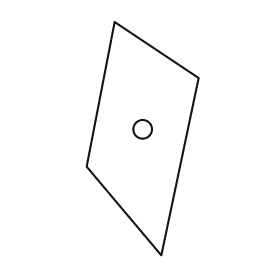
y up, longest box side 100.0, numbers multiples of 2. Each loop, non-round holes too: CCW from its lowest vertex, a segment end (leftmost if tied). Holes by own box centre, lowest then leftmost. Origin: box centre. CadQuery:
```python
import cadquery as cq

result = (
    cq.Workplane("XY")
    .moveTo(8.0, -50.0)
    .lineTo(24.0, 26.0)
    .lineTo(-12.0, 50.0)
    .lineTo(-24.0, -12.0)
    .close()
    .moveTo(0.0, 4.0)
    .circle(4.0)
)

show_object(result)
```